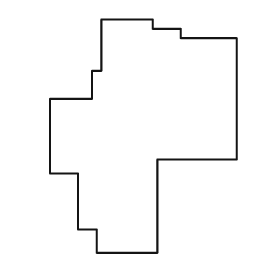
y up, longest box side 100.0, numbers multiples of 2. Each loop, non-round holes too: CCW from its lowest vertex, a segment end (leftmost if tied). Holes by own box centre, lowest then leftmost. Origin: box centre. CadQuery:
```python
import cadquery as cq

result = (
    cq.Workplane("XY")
    .moveTo(-20.0, -50.0)
    .lineTo(6.0, -50.0)
    .lineTo(6.0, -10.0)
    .lineTo(40.0, -10.0)
    .lineTo(40.0, 42.0)
    .lineTo(16.0, 42.0)
    .lineTo(16.0, 46.0)
    .lineTo(4.0, 46.0)
    .lineTo(4.0, 50.0)
    .lineTo(-18.0, 50.0)
    .lineTo(-18.0, 28.0)
    .lineTo(-22.0, 28.0)
    .lineTo(-22.0, 16.0)
    .lineTo(-40.0, 16.0)
    .lineTo(-40.0, -16.0)
    .lineTo(-28.0, -16.0)
    .lineTo(-28.0, -40.0)
    .lineTo(-20.0, -40.0)
    .close()
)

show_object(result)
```